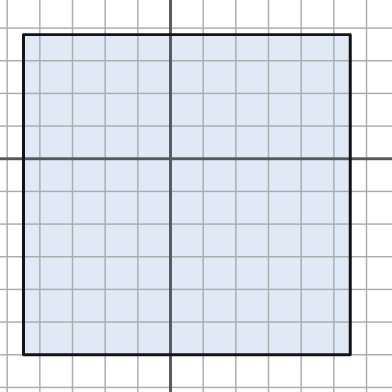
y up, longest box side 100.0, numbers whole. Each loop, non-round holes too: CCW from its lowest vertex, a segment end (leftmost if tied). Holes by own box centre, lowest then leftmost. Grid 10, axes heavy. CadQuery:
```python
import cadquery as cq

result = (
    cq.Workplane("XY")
    .moveTo(-45.0, -60.0)
    .lineTo(55.0, -60.0)
    .lineTo(55.0, 38.0)
    .lineTo(-45.0, 38.0)
    .close()
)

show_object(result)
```